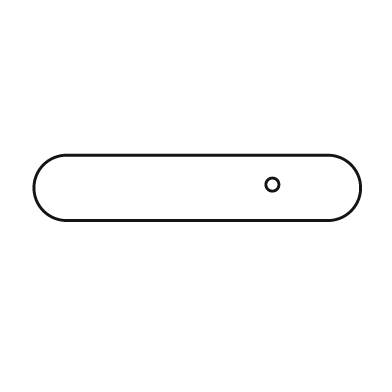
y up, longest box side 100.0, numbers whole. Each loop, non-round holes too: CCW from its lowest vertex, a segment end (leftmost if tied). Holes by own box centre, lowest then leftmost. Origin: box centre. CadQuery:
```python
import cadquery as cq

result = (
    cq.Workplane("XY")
    .moveTo(-40.0, -10.0)
    .lineTo(40.0, -10.0)
    .threePointArc((50.0, 0.0), (40.0, 10.0))
    .lineTo(-40.0, 10.0)
    .threePointArc((-50.0, 0.0), (-40.0, -10.0))
    .close()
    .moveTo(23.0, 1.0)
    .circle(2.0)
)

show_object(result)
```